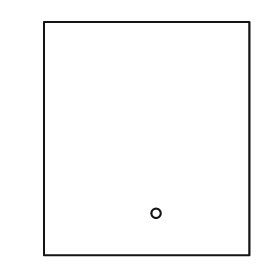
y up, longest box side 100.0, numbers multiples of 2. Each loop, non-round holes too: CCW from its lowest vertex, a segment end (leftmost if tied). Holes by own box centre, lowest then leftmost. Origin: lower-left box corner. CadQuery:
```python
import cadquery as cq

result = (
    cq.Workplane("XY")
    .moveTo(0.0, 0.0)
    .lineTo(88.0, 0.0)
    .lineTo(88.0, 100.0)
    .lineTo(0.0, 100.0)
    .close()
    .moveTo(48.0, 18.0)
    .circle(2.0)
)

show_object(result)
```